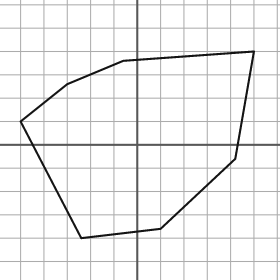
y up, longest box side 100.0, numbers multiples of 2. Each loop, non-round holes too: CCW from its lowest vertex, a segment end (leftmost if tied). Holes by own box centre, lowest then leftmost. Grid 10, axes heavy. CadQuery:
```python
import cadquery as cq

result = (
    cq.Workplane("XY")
    .moveTo(-24.0, -40.0)
    .lineTo(10.0, -36.0)
    .lineTo(42.0, -6.0)
    .lineTo(50.0, 40.0)
    .lineTo(-6.0, 36.0)
    .lineTo(-30.0, 26.0)
    .lineTo(-50.0, 10.0)
    .close()
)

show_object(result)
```